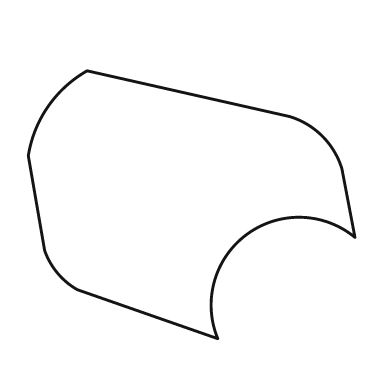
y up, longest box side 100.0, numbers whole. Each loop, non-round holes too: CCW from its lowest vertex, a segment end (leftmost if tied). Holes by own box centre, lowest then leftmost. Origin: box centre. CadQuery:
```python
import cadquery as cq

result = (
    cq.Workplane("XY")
    .moveTo(8.0, -41.0)
    .threePointArc((17.0, -9.0), (50.0, -10.0))
    .lineTo(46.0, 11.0)
    .threePointArc((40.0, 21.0), (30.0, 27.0))
    .lineTo(-32.0, 41.0)
    .threePointArc((-44.0, 30.0), (-50.0, 15.0))
    .lineTo(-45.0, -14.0)
    .threePointArc((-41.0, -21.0), (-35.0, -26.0))
    .close()
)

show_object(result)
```